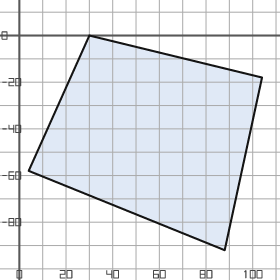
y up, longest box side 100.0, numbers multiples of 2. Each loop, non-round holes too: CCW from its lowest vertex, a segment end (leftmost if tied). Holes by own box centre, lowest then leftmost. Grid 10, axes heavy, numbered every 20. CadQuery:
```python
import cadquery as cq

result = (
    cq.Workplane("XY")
    .moveTo(88.0, -92.0)
    .lineTo(104.0, -18.0)
    .lineTo(30.0, 0.0)
    .lineTo(4.0, -58.0)
    .close()
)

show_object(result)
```